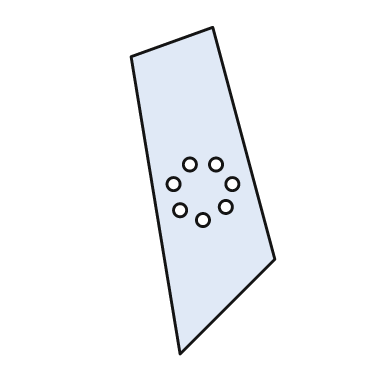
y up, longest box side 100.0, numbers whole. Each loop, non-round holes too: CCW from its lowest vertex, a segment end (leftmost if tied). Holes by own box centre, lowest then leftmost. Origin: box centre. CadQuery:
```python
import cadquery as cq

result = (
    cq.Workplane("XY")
    .moveTo(-7.0, -50.0)
    .lineTo(22.0, -21.0)
    .lineTo(3.0, 50.0)
    .lineTo(-22.0, 41.0)
    .close()
    .moveTo(0.0, -9.0)
    .circle(2.0)
    .moveTo(-7.0, -6.0)
    .circle(2.0)
    .moveTo(7.0, -5.0)
    .circle(2.0)
    .moveTo(-9.0, 2.0)
    .circle(2.0)
    .moveTo(9.0, 2.0)
    .circle(2.0)
    .moveTo(-4.0, 8.0)
    .circle(2.0)
    .moveTo(4.0, 8.0)
    .circle(2.0)
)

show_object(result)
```